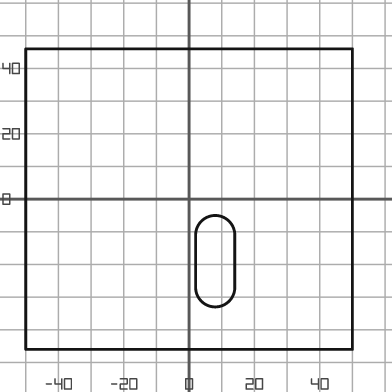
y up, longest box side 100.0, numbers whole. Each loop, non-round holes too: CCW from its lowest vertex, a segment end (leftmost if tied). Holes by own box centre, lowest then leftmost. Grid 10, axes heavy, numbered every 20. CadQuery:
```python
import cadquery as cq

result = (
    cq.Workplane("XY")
    .moveTo(-50.0, -46.0)
    .lineTo(50.0, -46.0)
    .lineTo(50.0, 46.0)
    .lineTo(-50.0, 46.0)
    .close()
    .moveTo(2.0, -27.0)
    .threePointArc((8.0, -33.0), (14.0, -27.0))
    .lineTo(14.0, -11.0)
    .threePointArc((8.0, -5.0), (2.0, -11.0))
    .close()
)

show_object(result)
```